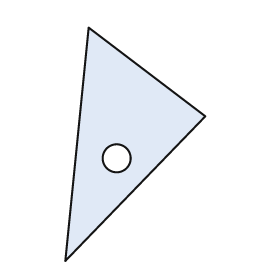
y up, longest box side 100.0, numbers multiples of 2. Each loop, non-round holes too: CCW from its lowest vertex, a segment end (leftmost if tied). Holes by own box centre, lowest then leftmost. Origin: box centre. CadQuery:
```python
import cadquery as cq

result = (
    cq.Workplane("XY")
    .moveTo(-30.0, -50.0)
    .lineTo(30.0, 12.0)
    .lineTo(-20.0, 50.0)
    .close()
    .moveTo(-8.0, -6.0)
    .circle(6.0)
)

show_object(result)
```